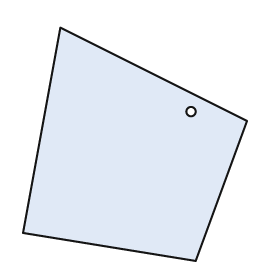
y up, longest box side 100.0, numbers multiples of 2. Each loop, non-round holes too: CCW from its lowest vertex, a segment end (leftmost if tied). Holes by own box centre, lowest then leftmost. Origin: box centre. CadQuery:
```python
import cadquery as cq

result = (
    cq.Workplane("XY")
    .moveTo(26.0, -50.0)
    .lineTo(48.0, 10.0)
    .lineTo(-32.0, 50.0)
    .lineTo(-48.0, -38.0)
    .close()
    .moveTo(24.0, 14.0)
    .circle(2.0)
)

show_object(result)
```